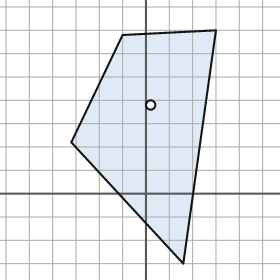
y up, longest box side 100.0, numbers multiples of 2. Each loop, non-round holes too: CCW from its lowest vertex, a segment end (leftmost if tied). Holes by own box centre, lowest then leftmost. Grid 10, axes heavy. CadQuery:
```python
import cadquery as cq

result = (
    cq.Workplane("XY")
    .moveTo(16.0, -30.0)
    .lineTo(30.0, 70.0)
    .lineTo(-10.0, 68.0)
    .lineTo(-32.0, 22.0)
    .close()
    .moveTo(2.0, 38.0)
    .circle(2.0)
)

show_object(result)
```